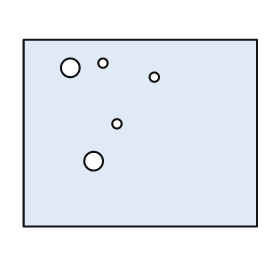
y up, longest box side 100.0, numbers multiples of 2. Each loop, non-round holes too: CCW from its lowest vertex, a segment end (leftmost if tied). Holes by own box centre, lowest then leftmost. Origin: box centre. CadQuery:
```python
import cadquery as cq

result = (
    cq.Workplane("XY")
    .moveTo(-50.0, -40.0)
    .lineTo(50.0, -40.0)
    .lineTo(50.0, 40.0)
    .lineTo(-50.0, 40.0)
    .close()
    .moveTo(-20.0, -12.0)
    .circle(4.0)
    .moveTo(-10.0, 4.0)
    .circle(2.0)
    .moveTo(6.0, 24.0)
    .circle(2.0)
    .moveTo(-30.0, 28.0)
    .circle(4.0)
    .moveTo(-16.0, 30.0)
    .circle(2.0)
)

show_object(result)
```